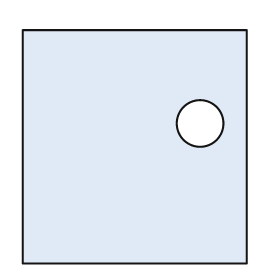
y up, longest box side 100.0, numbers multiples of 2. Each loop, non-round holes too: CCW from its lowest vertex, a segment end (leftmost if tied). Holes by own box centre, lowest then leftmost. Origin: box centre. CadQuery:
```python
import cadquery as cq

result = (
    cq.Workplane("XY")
    .moveTo(-48.0, -50.0)
    .lineTo(48.0, -50.0)
    .lineTo(48.0, 50.0)
    .lineTo(-48.0, 50.0)
    .close()
    .moveTo(28.0, 10.0)
    .circle(10.0)
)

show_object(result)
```